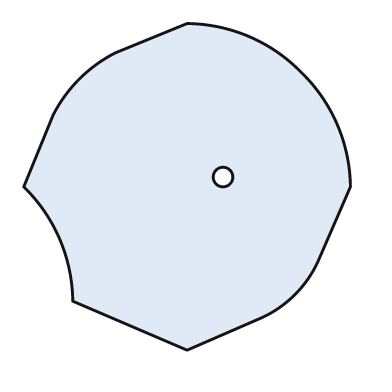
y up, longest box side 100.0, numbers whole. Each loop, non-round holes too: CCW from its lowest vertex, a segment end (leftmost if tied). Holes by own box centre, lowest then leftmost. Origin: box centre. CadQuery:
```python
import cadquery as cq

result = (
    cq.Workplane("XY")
    .moveTo(0.0, -50.0)
    .lineTo(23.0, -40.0)
    .threePointArc((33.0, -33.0), (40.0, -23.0))
    .lineTo(50.0, 0.0)
    .threePointArc((46.0, 19.0), (35.0, 35.0))
    .threePointArc((19.0, 46.0), (0.0, 50.0))
    .lineTo(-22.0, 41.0)
    .threePointArc((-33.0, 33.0), (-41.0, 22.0))
    .lineTo(-50.0, 0.0)
    .threePointArc((-39.0, -16.0), (-35.0, -35.0))
    .close()
    .moveTo(11.0, 3.0)
    .circle(3.0)
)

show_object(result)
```